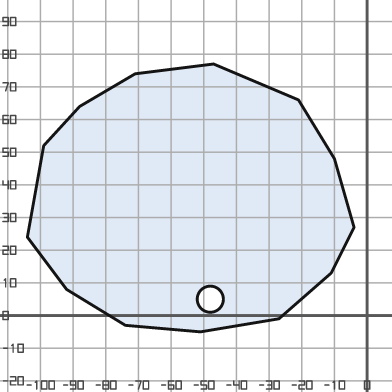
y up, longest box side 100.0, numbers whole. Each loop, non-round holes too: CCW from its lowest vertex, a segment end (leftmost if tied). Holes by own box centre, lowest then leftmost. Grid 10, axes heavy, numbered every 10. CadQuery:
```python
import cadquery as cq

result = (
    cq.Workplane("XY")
    .moveTo(-51.0, -5.0)
    .lineTo(-27.0, -1.0)
    .lineTo(-11.0, 13.0)
    .lineTo(-4.0, 27.0)
    .lineTo(-10.0, 48.0)
    .lineTo(-21.0, 66.0)
    .lineTo(-47.0, 77.0)
    .lineTo(-71.0, 74.0)
    .lineTo(-88.0, 64.0)
    .lineTo(-99.0, 52.0)
    .lineTo(-104.0, 24.0)
    .lineTo(-92.0, 8.0)
    .lineTo(-74.0, -3.0)
    .close()
    .moveTo(-48.0, 5.0)
    .circle(4.0)
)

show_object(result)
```